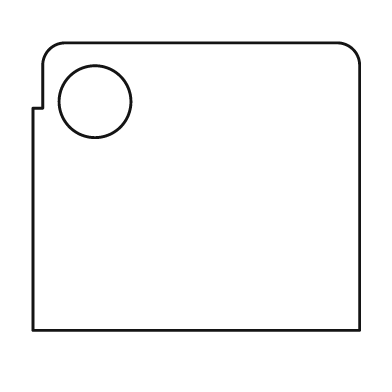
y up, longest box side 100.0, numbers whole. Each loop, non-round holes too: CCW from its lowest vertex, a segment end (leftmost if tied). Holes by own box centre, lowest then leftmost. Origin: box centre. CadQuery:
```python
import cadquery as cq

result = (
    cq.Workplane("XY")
    .moveTo(-50.0, -44.0)
    .lineTo(50.0, -44.0)
    .lineTo(50.0, 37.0)
    .threePointArc((48.0, 42.0), (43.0, 44.0))
    .lineTo(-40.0, 44.0)
    .threePointArc((-45.0, 42.0), (-47.0, 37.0))
    .lineTo(-47.0, 24.0)
    .lineTo(-50.0, 24.0)
    .close()
    .moveTo(-31.0, 26.0)
    .circle(11.0)
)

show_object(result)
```